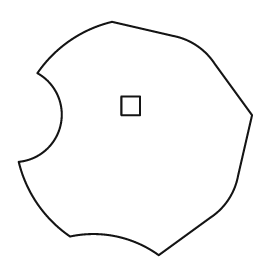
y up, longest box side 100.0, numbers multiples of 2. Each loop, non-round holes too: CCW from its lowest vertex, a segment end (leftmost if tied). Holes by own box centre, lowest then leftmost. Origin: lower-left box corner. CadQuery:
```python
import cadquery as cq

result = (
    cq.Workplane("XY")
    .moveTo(60.0, 0.0)
    .lineTo(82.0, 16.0)
    .threePointArc((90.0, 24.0), (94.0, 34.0))
    .lineTo(100.0, 60.0)
    .lineTo(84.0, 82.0)
    .threePointArc((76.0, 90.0), (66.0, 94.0))
    .lineTo(40.0, 100.0)
    .threePointArc((22.0, 92.0), (8.0, 78.0))
    .threePointArc((18.0, 56.0), (0.0, 40.0))
    .threePointArc((8.0, 22.0), (22.0, 8.0))
    .threePointArc((42.0, 8.0), (60.0, 0.0))
    .close()
    .moveTo(44.0, 60.0)
    .lineTo(52.0, 60.0)
    .lineTo(52.0, 68.0)
    .lineTo(44.0, 68.0)
    .close()
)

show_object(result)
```